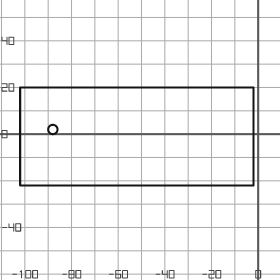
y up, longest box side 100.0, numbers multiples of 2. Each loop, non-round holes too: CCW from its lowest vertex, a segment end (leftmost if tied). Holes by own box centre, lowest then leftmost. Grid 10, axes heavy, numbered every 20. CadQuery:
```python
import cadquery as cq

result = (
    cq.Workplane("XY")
    .moveTo(-102.0, -22.0)
    .lineTo(-2.0, -22.0)
    .lineTo(-2.0, 20.0)
    .lineTo(-102.0, 20.0)
    .close()
    .moveTo(-88.0, 2.0)
    .circle(2.0)
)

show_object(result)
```